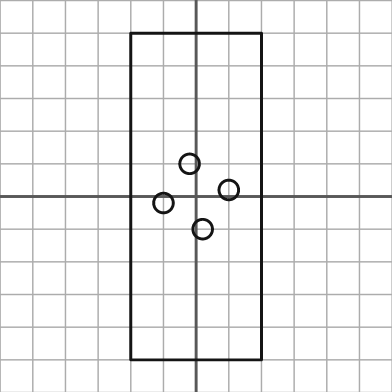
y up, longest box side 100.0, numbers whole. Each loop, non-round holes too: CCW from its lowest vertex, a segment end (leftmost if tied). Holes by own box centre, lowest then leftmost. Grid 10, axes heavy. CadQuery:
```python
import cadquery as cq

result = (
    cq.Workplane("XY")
    .moveTo(-20.0, -50.0)
    .lineTo(20.0, -50.0)
    .lineTo(20.0, 50.0)
    .lineTo(-20.0, 50.0)
    .close()
    .moveTo(2.0, -10.0)
    .circle(3.0)
    .moveTo(-10.0, -2.0)
    .circle(3.0)
    .moveTo(10.0, 2.0)
    .circle(3.0)
    .moveTo(-2.0, 10.0)
    .circle(3.0)
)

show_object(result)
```